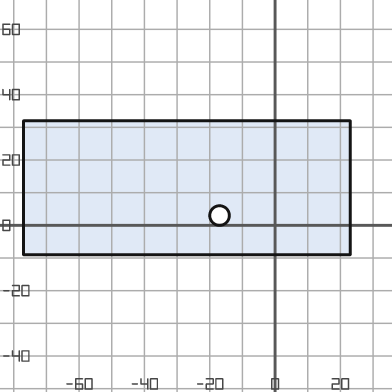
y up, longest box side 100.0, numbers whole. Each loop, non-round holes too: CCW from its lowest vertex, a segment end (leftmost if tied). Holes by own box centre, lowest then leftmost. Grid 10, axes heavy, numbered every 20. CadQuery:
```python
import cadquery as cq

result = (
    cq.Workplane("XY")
    .moveTo(-77.0, -9.0)
    .lineTo(23.0, -9.0)
    .lineTo(23.0, 32.0)
    .lineTo(-77.0, 32.0)
    .close()
    .moveTo(-17.0, 3.0)
    .circle(3.0)
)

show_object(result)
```